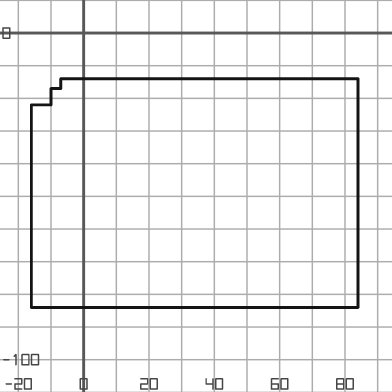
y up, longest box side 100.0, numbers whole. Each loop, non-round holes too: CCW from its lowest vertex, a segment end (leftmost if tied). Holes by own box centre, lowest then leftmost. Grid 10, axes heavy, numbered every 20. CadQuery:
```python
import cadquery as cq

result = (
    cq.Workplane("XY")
    .moveTo(-16.0, -84.0)
    .lineTo(84.0, -84.0)
    .lineTo(84.0, -14.0)
    .lineTo(-7.0, -14.0)
    .lineTo(-7.0, -17.0)
    .lineTo(-10.0, -17.0)
    .lineTo(-10.0, -22.0)
    .lineTo(-16.0, -22.0)
    .close()
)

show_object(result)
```